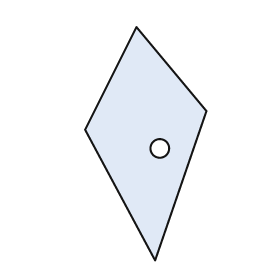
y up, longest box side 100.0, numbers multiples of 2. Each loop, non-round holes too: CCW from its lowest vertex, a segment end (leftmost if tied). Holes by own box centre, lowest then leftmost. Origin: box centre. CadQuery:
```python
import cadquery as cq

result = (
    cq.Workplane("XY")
    .moveTo(4.0, -50.0)
    .lineTo(26.0, 14.0)
    .lineTo(-4.0, 50.0)
    .lineTo(-26.0, 6.0)
    .close()
    .moveTo(6.0, -2.0)
    .circle(4.0)
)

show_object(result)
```